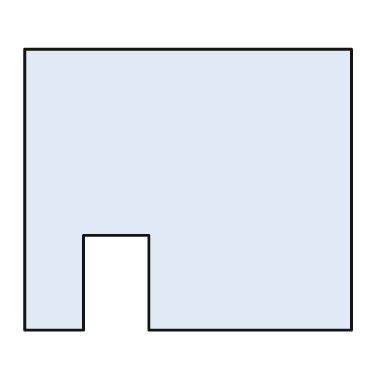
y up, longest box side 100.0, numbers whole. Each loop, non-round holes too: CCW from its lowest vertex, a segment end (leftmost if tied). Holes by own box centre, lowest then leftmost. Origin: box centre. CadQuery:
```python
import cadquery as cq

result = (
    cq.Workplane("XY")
    .moveTo(-50.0, -43.0)
    .lineTo(-32.0, -43.0)
    .lineTo(-32.0, -14.0)
    .lineTo(-12.0, -14.0)
    .lineTo(-12.0, -43.0)
    .lineTo(50.0, -43.0)
    .lineTo(50.0, 43.0)
    .lineTo(-50.0, 43.0)
    .close()
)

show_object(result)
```